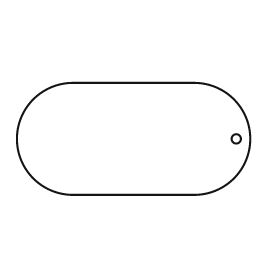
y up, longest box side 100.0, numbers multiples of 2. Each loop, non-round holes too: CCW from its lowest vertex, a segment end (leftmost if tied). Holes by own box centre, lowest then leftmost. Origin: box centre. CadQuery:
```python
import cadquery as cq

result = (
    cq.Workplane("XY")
    .moveTo(-26.0, -24.0)
    .lineTo(26.0, -24.0)
    .threePointArc((50.0, 0.0), (26.0, 24.0))
    .lineTo(-26.0, 24.0)
    .threePointArc((-50.0, 0.0), (-26.0, -24.0))
    .close()
    .moveTo(44.0, 0.0)
    .circle(2.0)
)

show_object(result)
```